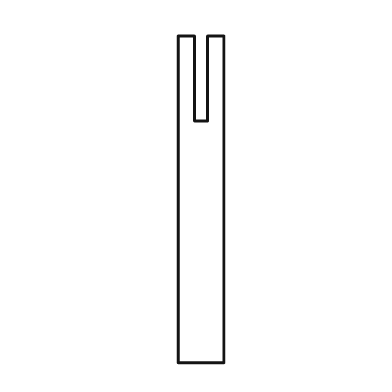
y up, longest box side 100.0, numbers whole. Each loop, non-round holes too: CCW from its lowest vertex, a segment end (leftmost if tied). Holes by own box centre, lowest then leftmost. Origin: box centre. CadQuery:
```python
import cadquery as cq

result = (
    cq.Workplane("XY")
    .moveTo(-7.0, -50.0)
    .lineTo(7.0, -50.0)
    .lineTo(7.0, 50.0)
    .lineTo(2.0, 50.0)
    .lineTo(2.0, 24.0)
    .lineTo(-2.0, 24.0)
    .lineTo(-2.0, 50.0)
    .lineTo(-7.0, 50.0)
    .close()
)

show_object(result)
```